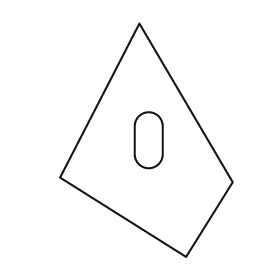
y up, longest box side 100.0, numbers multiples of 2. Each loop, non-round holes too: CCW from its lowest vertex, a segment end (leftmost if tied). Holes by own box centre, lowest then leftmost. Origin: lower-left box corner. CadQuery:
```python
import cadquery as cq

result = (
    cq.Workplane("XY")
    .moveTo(54.0, 0.0)
    .lineTo(74.0, 32.0)
    .lineTo(34.0, 100.0)
    .lineTo(0.0, 34.0)
    .close()
    .moveTo(32.0, 44.0)
    .threePointArc((38.0, 38.0), (44.0, 44.0))
    .lineTo(44.0, 56.0)
    .threePointArc((38.0, 62.0), (32.0, 56.0))
    .close()
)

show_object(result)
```